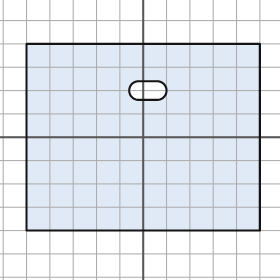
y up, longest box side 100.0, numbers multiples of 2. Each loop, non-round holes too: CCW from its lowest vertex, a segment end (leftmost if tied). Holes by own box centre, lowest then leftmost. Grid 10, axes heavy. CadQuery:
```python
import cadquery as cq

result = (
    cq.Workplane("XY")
    .moveTo(-50.0, -40.0)
    .lineTo(50.0, -40.0)
    .lineTo(50.0, 40.0)
    .lineTo(-50.0, 40.0)
    .close()
    .moveTo(-2.0, 16.0)
    .lineTo(6.0, 16.0)
    .threePointArc((10.0, 20.0), (6.0, 24.0))
    .lineTo(-2.0, 24.0)
    .threePointArc((-6.0, 20.0), (-2.0, 16.0))
    .close()
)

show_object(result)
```